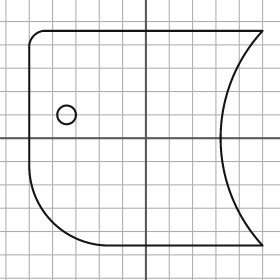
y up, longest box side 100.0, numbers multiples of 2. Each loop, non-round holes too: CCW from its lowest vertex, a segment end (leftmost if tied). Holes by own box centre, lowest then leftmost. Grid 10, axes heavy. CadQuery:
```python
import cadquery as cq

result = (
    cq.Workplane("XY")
    .moveTo(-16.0, -46.0)
    .lineTo(50.0, -46.0)
    .threePointArc((32.0, 0.0), (50.0, 46.0))
    .lineTo(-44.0, 46.0)
    .threePointArc((-48.0, 44.0), (-50.0, 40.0))
    .lineTo(-50.0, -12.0)
    .threePointArc((-40.0, -36.0), (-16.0, -46.0))
    .close()
    .moveTo(-34.0, 10.0)
    .circle(4.0)
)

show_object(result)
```